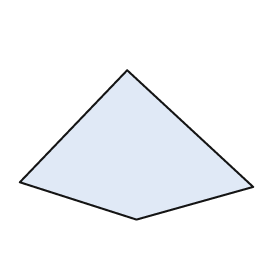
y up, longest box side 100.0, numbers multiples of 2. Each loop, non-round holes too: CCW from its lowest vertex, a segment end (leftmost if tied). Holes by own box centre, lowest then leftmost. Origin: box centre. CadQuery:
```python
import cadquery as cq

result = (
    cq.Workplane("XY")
    .moveTo(0.0, -32.0)
    .lineTo(50.0, -18.0)
    .lineTo(-4.0, 32.0)
    .lineTo(-50.0, -16.0)
    .close()
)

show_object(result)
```